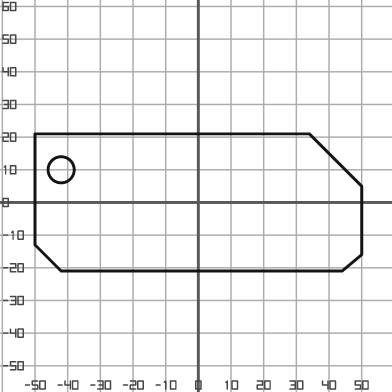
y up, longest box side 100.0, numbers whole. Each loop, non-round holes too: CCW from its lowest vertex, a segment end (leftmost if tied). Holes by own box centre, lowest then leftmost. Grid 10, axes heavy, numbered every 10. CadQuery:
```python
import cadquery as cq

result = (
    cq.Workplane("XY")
    .moveTo(-42.0, -21.0)
    .lineTo(44.0, -21.0)
    .lineTo(50.0, -16.0)
    .lineTo(50.0, 5.0)
    .lineTo(34.0, 21.0)
    .lineTo(-50.0, 21.0)
    .lineTo(-50.0, -13.0)
    .close()
    .moveTo(-42.0, 10.0)
    .circle(4.0)
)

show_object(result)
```